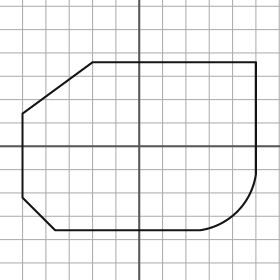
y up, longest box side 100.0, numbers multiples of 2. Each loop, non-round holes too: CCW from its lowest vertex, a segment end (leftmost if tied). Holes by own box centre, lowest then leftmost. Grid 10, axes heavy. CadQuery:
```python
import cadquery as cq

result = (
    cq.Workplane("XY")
    .moveTo(-36.0, -36.0)
    .lineTo(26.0, -36.0)
    .threePointArc((42.0, -28.0), (50.0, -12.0))
    .lineTo(50.0, 36.0)
    .lineTo(-20.0, 36.0)
    .lineTo(-50.0, 14.0)
    .lineTo(-50.0, -22.0)
    .close()
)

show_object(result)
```